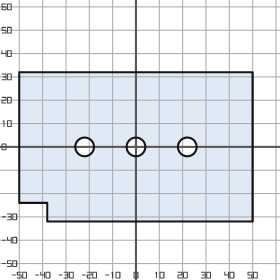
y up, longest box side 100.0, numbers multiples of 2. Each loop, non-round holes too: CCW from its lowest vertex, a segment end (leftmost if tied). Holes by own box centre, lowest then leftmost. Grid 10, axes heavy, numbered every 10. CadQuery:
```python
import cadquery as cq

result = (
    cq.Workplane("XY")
    .moveTo(-38.0, -32.0)
    .lineTo(50.0, -32.0)
    .lineTo(50.0, 32.0)
    .lineTo(-50.0, 32.0)
    .lineTo(-50.0, -24.0)
    .lineTo(-38.0, -24.0)
    .close()
    .moveTo(-22.0, 0.0)
    .circle(4.0)
    .moveTo(0.0, 0.0)
    .circle(4.0)
    .moveTo(22.0, 0.0)
    .circle(4.0)
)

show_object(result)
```